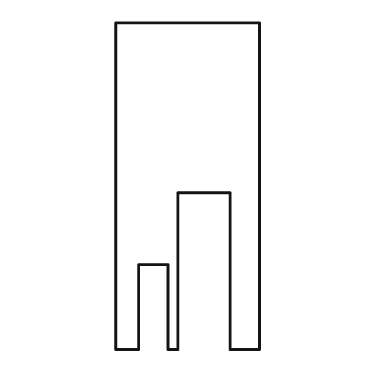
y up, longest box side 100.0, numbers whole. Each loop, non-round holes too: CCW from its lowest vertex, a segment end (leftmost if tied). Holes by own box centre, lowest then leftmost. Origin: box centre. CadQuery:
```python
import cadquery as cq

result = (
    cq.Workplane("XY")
    .moveTo(-22.0, -50.0)
    .lineTo(-15.0, -50.0)
    .lineTo(-15.0, -24.0)
    .lineTo(-6.0, -24.0)
    .lineTo(-6.0, -50.0)
    .lineTo(-3.0, -50.0)
    .lineTo(-3.0, -2.0)
    .lineTo(13.0, -2.0)
    .lineTo(13.0, -50.0)
    .lineTo(22.0, -50.0)
    .lineTo(22.0, 50.0)
    .lineTo(-22.0, 50.0)
    .close()
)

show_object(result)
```